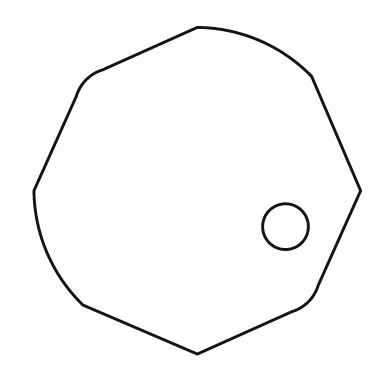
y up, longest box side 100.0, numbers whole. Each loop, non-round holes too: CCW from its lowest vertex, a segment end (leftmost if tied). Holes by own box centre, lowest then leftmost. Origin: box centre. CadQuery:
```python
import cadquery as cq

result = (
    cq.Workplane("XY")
    .moveTo(0.0, -50.0)
    .lineTo(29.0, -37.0)
    .threePointArc((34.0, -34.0), (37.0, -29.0))
    .lineTo(50.0, 0.0)
    .lineTo(35.0, 35.0)
    .threePointArc((19.0, 46.0), (0.0, 50.0))
    .lineTo(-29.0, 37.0)
    .threePointArc((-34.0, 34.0), (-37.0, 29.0))
    .lineTo(-50.0, 0.0)
    .threePointArc((-46.0, -19.0), (-35.0, -35.0))
    .close()
    .moveTo(27.0, -11.0)
    .circle(7.0)
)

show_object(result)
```